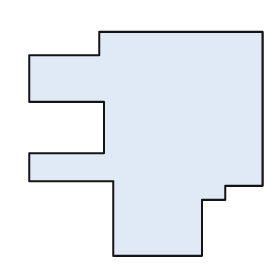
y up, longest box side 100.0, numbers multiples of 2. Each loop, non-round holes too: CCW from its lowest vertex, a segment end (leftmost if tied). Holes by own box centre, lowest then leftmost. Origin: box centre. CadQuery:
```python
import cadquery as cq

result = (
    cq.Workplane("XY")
    .moveTo(-14.0, -48.0)
    .lineTo(24.0, -48.0)
    .lineTo(24.0, -24.0)
    .lineTo(34.0, -24.0)
    .lineTo(34.0, -18.0)
    .lineTo(50.0, -18.0)
    .lineTo(50.0, 48.0)
    .lineTo(-20.0, 48.0)
    .lineTo(-20.0, 38.0)
    .lineTo(-50.0, 38.0)
    .lineTo(-50.0, 18.0)
    .lineTo(-18.0, 18.0)
    .lineTo(-18.0, -4.0)
    .lineTo(-50.0, -4.0)
    .lineTo(-50.0, -16.0)
    .lineTo(-14.0, -16.0)
    .close()
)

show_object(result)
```